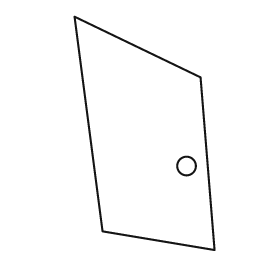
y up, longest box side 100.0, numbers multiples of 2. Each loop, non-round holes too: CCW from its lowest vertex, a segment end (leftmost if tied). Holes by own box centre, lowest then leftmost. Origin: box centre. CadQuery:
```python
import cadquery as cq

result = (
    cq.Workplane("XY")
    .moveTo(30.0, -50.0)
    .lineTo(24.0, 24.0)
    .lineTo(-30.0, 50.0)
    .lineTo(-18.0, -42.0)
    .close()
    .moveTo(18.0, -14.0)
    .circle(4.0)
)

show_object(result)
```